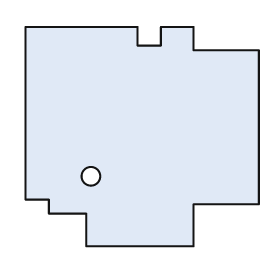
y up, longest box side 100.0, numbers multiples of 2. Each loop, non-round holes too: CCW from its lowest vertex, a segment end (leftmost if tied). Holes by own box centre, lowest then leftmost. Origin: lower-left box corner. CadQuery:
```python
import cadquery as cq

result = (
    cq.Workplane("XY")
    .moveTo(26.0, 0.0)
    .lineTo(72.0, 0.0)
    .lineTo(72.0, 18.0)
    .lineTo(100.0, 18.0)
    .lineTo(100.0, 84.0)
    .lineTo(72.0, 84.0)
    .lineTo(72.0, 94.0)
    .lineTo(58.0, 94.0)
    .lineTo(58.0, 86.0)
    .lineTo(48.0, 86.0)
    .lineTo(48.0, 94.0)
    .lineTo(0.0, 94.0)
    .lineTo(0.0, 20.0)
    .lineTo(10.0, 20.0)
    .lineTo(10.0, 14.0)
    .lineTo(26.0, 14.0)
    .close()
    .moveTo(28.0, 30.0)
    .circle(4.0)
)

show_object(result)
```